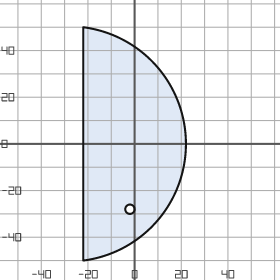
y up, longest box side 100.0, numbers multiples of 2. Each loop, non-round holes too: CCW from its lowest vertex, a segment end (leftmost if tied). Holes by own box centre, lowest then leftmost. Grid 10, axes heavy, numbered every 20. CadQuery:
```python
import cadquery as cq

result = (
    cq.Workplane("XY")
    .moveTo(-22.0, -50.0)
    .threePointArc((22.0, 0.0), (-22.0, 50.0))
    .close()
    .moveTo(-2.0, -28.0)
    .circle(2.0)
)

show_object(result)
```